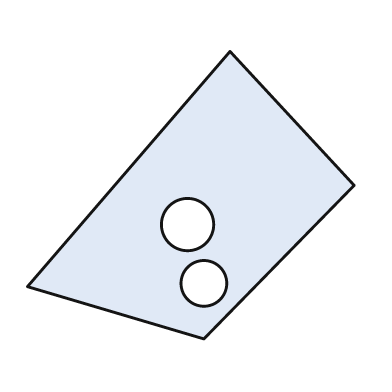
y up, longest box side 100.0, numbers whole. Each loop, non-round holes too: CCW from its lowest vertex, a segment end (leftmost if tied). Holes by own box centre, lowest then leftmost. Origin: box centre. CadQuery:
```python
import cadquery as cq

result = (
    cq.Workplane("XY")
    .moveTo(4.0, -44.0)
    .lineTo(50.0, 3.0)
    .lineTo(12.0, 44.0)
    .lineTo(-50.0, -28.0)
    .close()
    .moveTo(4.0, -27.0)
    .circle(7.0)
    .moveTo(-1.0, -9.0)
    .circle(8.0)
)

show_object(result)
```